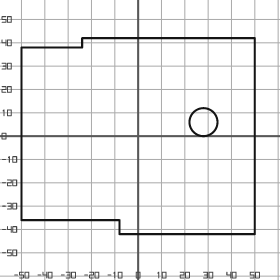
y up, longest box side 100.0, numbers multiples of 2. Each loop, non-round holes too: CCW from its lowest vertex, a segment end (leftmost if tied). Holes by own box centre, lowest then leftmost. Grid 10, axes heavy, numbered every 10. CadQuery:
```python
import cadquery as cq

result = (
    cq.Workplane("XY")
    .moveTo(-8.0, -42.0)
    .lineTo(50.0, -42.0)
    .lineTo(50.0, 42.0)
    .lineTo(-24.0, 42.0)
    .lineTo(-24.0, 38.0)
    .lineTo(-50.0, 38.0)
    .lineTo(-50.0, -36.0)
    .lineTo(-8.0, -36.0)
    .close()
    .moveTo(28.0, 6.0)
    .circle(6.0)
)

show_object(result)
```